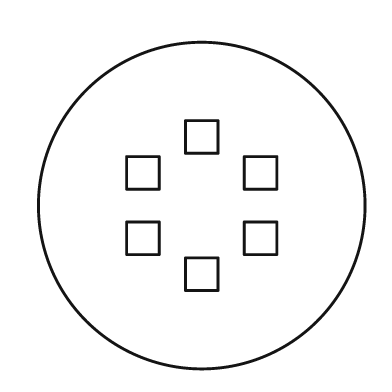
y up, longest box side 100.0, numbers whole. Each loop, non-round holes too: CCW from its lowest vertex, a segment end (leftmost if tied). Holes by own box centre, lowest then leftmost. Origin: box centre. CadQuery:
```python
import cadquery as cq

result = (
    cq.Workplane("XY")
    .moveTo(0.0, 0.0)
    .circle(50.0)
    .moveTo(-5.0, -26.0)
    .lineTo(5.0, -26.0)
    .lineTo(5.0, -16.0)
    .lineTo(-5.0, -16.0)
    .close()
    .moveTo(-23.0, -15.0)
    .lineTo(-13.0, -15.0)
    .lineTo(-13.0, -5.0)
    .lineTo(-23.0, -5.0)
    .close()
    .moveTo(13.0, -15.0)
    .lineTo(23.0, -15.0)
    .lineTo(23.0, -5.0)
    .lineTo(13.0, -5.0)
    .close()
    .moveTo(-23.0, 5.0)
    .lineTo(-13.0, 5.0)
    .lineTo(-13.0, 15.0)
    .lineTo(-23.0, 15.0)
    .close()
    .moveTo(13.0, 5.0)
    .lineTo(23.0, 5.0)
    .lineTo(23.0, 15.0)
    .lineTo(13.0, 15.0)
    .close()
    .moveTo(-5.0, 16.0)
    .lineTo(5.0, 16.0)
    .lineTo(5.0, 26.0)
    .lineTo(-5.0, 26.0)
    .close()
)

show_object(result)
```